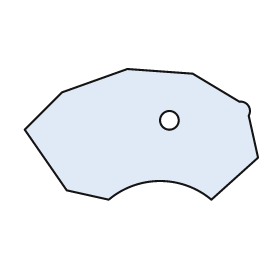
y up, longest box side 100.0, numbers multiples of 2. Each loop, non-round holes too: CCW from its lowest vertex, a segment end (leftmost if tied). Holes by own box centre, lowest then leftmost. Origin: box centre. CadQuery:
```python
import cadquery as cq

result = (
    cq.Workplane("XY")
    .moveTo(-14.0, -28.0)
    .threePointArc((8.0, -20.0), (30.0, -28.0))
    .lineTo(50.0, -10.0)
    .lineTo(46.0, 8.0)
    .threePointArc((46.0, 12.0), (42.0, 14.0))
    .lineTo(22.0, 26.0)
    .lineTo(-6.0, 28.0)
    .lineTo(-34.0, 18.0)
    .lineTo(-50.0, 2.0)
    .lineTo(-32.0, -24.0)
    .close()
    .moveTo(12.0, 6.0)
    .circle(4.0)
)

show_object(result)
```